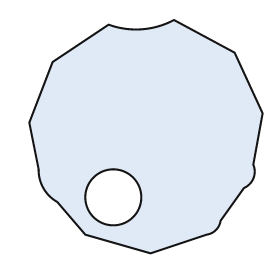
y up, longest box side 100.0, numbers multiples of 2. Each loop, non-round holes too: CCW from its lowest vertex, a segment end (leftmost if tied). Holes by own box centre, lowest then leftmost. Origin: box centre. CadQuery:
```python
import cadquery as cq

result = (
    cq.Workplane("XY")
    .moveTo(2.0, -50.0)
    .lineTo(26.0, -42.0)
    .threePointArc((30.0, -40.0), (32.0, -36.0))
    .lineTo(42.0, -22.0)
    .threePointArc((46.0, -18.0), (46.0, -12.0))
    .lineTo(50.0, 10.0)
    .lineTo(38.0, 36.0)
    .lineTo(12.0, 50.0)
    .threePointArc((-2.0, 46.0), (-16.0, 48.0))
    .lineTo(-40.0, 32.0)
    .lineTo(-50.0, 6.0)
    .lineTo(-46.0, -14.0)
    .threePointArc((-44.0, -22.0), (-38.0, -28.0))
    .lineTo(-26.0, -42.0)
    .close()
    .moveTo(-14.0, -26.0)
    .circle(12.0)
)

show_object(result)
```